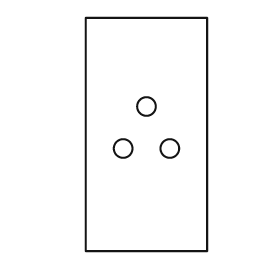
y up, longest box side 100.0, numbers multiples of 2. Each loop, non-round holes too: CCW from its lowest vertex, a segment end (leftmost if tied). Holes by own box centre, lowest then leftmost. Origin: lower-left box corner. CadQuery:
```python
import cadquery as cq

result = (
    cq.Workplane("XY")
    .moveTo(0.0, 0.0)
    .lineTo(52.0, 0.0)
    .lineTo(52.0, 100.0)
    .lineTo(0.0, 100.0)
    .close()
    .moveTo(16.0, 44.0)
    .circle(4.0)
    .moveTo(36.0, 44.0)
    .circle(4.0)
    .moveTo(26.0, 62.0)
    .circle(4.0)
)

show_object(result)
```